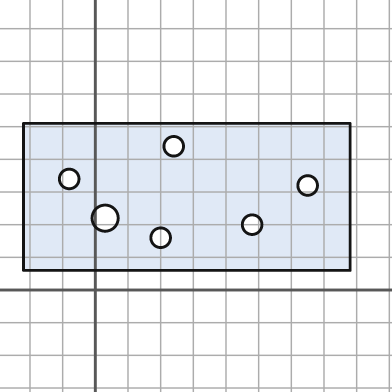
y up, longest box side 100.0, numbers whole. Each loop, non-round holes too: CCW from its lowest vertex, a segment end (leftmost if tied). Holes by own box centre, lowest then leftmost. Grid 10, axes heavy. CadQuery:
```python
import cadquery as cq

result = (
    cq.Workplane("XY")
    .moveTo(-22.0, 6.0)
    .lineTo(78.0, 6.0)
    .lineTo(78.0, 51.0)
    .lineTo(-22.0, 51.0)
    .close()
    .moveTo(20.0, 16.0)
    .circle(3.0)
    .moveTo(48.0, 20.0)
    .circle(3.0)
    .moveTo(3.0, 22.0)
    .circle(4.0)
    .moveTo(65.0, 32.0)
    .circle(3.0)
    .moveTo(-8.0, 34.0)
    .circle(3.0)
    .moveTo(24.0, 44.0)
    .circle(3.0)
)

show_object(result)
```